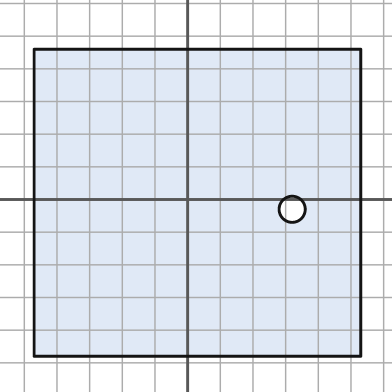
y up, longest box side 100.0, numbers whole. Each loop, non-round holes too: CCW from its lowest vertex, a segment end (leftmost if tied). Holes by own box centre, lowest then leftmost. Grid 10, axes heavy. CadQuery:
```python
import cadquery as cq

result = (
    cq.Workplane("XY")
    .moveTo(-47.0, -48.0)
    .lineTo(53.0, -48.0)
    .lineTo(53.0, 46.0)
    .lineTo(-47.0, 46.0)
    .close()
    .moveTo(32.0, -3.0)
    .circle(4.0)
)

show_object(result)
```